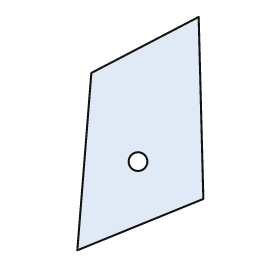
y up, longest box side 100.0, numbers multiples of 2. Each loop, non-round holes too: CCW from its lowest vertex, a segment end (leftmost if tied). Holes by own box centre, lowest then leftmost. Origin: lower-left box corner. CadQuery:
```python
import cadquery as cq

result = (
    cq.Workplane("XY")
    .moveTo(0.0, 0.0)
    .lineTo(54.0, 22.0)
    .lineTo(52.0, 100.0)
    .lineTo(6.0, 76.0)
    .close()
    .moveTo(26.0, 38.0)
    .circle(4.0)
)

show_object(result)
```